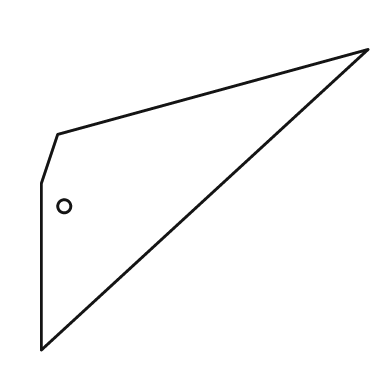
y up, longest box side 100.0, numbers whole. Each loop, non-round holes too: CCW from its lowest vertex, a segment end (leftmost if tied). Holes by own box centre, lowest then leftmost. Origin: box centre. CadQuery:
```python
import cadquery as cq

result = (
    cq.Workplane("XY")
    .moveTo(-50.0, -46.0)
    .lineTo(50.0, 46.0)
    .lineTo(-45.0, 20.0)
    .lineTo(-50.0, 5.0)
    .close()
    .moveTo(-43.0, -2.0)
    .circle(2.0)
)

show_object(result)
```